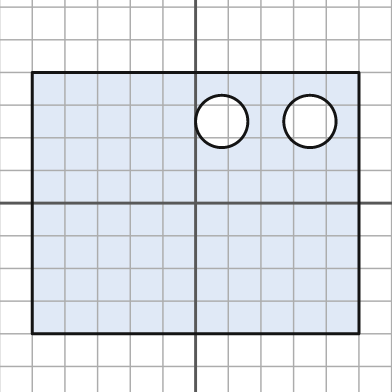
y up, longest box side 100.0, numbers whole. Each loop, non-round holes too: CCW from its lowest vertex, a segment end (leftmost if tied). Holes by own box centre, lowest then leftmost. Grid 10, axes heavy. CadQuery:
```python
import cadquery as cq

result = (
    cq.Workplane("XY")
    .moveTo(-50.0, -40.0)
    .lineTo(50.0, -40.0)
    .lineTo(50.0, 40.0)
    .lineTo(-50.0, 40.0)
    .close()
    .moveTo(8.0, 25.0)
    .circle(8.0)
    .moveTo(35.0, 25.0)
    .circle(8.0)
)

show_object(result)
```